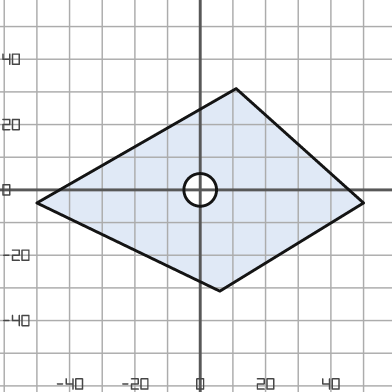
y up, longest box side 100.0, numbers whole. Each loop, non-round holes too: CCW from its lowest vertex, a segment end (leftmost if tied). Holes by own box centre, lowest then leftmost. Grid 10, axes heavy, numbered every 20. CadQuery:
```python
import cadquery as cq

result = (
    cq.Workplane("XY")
    .moveTo(6.0, -31.0)
    .lineTo(50.0, -4.0)
    .lineTo(11.0, 31.0)
    .lineTo(-50.0, -4.0)
    .close()
    .moveTo(0.0, 0.0)
    .circle(5.0)
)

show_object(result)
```